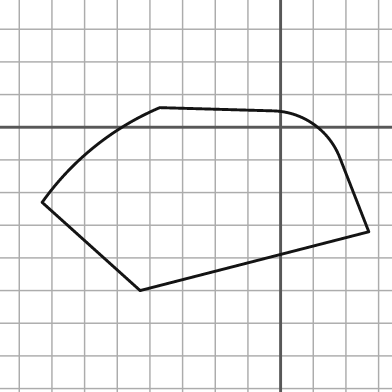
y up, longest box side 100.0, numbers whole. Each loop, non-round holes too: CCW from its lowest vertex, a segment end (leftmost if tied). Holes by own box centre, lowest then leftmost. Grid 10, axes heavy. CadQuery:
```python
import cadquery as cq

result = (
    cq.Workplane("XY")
    .moveTo(-43.0, -50.0)
    .lineTo(27.0, -32.0)
    .lineTo(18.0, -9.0)
    .threePointArc((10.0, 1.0), (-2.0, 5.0))
    .lineTo(-37.0, 6.0)
    .threePointArc((-57.0, -6.0), (-73.0, -23.0))
    .close()
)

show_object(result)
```